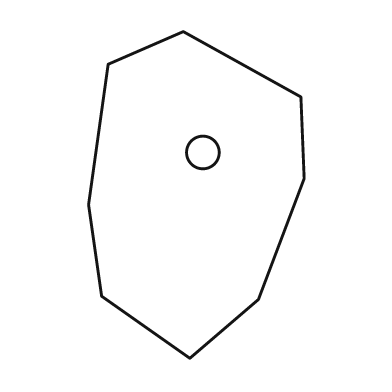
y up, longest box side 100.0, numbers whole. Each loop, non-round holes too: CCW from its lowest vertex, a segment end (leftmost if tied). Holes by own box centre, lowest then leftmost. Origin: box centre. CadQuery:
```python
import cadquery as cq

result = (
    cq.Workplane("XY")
    .moveTo(-2.0, -50.0)
    .lineTo(19.0, -32.0)
    .lineTo(33.0, 5.0)
    .lineTo(32.0, 30.0)
    .lineTo(-4.0, 50.0)
    .lineTo(-27.0, 40.0)
    .lineTo(-33.0, -3.0)
    .lineTo(-29.0, -31.0)
    .close()
    .moveTo(2.0, 13.0)
    .circle(5.0)
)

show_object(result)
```